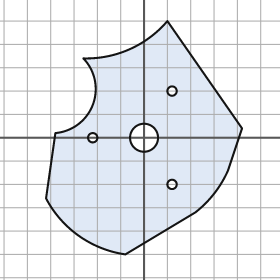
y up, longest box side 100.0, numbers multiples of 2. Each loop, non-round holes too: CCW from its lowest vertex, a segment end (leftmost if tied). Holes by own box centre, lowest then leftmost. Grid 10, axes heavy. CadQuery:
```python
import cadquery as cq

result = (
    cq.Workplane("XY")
    .moveTo(-8.0, -50.0)
    .lineTo(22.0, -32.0)
    .threePointArc((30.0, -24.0), (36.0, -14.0))
    .lineTo(42.0, 4.0)
    .lineTo(10.0, 50.0)
    .threePointArc((-6.0, 38.0), (-26.0, 34.0))
    .threePointArc((-22.0, 14.0), (-38.0, 2.0))
    .lineTo(-42.0, -26.0)
    .threePointArc((-28.0, -42.0), (-8.0, -50.0))
    .close()
    .moveTo(12.0, -20.0)
    .circle(2.0)
    .moveTo(-22.0, 0.0)
    .circle(2.0)
    .moveTo(0.0, 0.0)
    .circle(6.0)
    .moveTo(12.0, 20.0)
    .circle(2.0)
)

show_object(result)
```